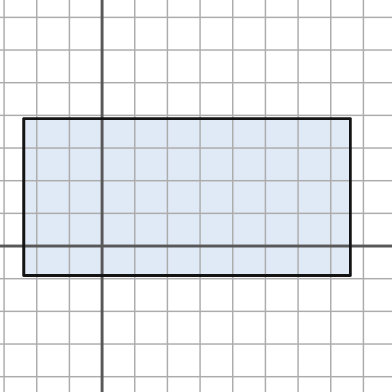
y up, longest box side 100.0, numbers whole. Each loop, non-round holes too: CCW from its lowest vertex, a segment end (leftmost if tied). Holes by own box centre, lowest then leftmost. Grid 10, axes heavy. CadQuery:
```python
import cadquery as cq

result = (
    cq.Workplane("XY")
    .moveTo(-24.0, -9.0)
    .lineTo(76.0, -9.0)
    .lineTo(76.0, 39.0)
    .lineTo(-24.0, 39.0)
    .close()
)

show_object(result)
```